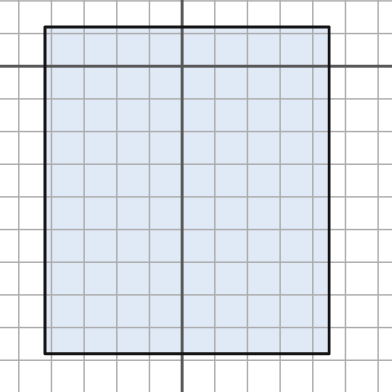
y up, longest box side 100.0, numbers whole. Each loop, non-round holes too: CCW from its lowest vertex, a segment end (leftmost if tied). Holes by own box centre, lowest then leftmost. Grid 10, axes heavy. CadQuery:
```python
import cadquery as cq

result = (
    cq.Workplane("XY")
    .moveTo(-42.0, -88.0)
    .lineTo(45.0, -88.0)
    .lineTo(45.0, 12.0)
    .lineTo(-42.0, 12.0)
    .close()
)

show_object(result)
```